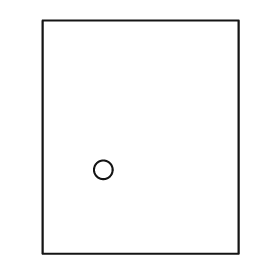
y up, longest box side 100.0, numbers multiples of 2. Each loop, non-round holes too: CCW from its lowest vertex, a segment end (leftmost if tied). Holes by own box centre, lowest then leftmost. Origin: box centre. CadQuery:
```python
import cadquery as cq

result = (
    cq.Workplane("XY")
    .moveTo(-42.0, -50.0)
    .lineTo(42.0, -50.0)
    .lineTo(42.0, 50.0)
    .lineTo(-42.0, 50.0)
    .close()
    .moveTo(-16.0, -14.0)
    .circle(4.0)
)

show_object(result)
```